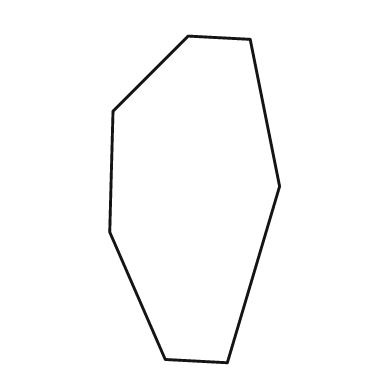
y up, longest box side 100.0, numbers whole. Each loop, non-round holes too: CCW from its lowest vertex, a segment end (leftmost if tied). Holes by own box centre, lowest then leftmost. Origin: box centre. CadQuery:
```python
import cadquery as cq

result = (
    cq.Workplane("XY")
    .moveTo(10.0, -50.0)
    .lineTo(26.0, 4.0)
    .lineTo(17.0, 49.0)
    .lineTo(-2.0, 50.0)
    .lineTo(-25.0, 27.0)
    .lineTo(-26.0, -10.0)
    .lineTo(-9.0, -49.0)
    .close()
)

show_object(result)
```